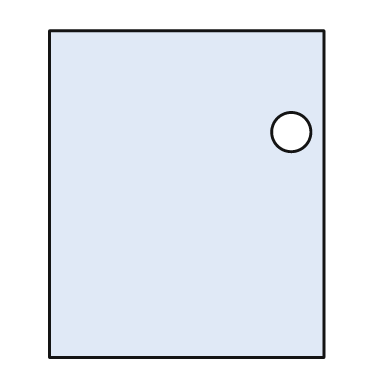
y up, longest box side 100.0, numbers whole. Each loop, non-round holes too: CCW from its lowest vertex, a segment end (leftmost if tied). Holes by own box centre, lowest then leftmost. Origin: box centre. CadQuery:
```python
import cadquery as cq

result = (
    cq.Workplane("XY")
    .moveTo(-42.0, -50.0)
    .lineTo(42.0, -50.0)
    .lineTo(42.0, 50.0)
    .lineTo(-42.0, 50.0)
    .close()
    .moveTo(32.0, 19.0)
    .circle(6.0)
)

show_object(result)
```